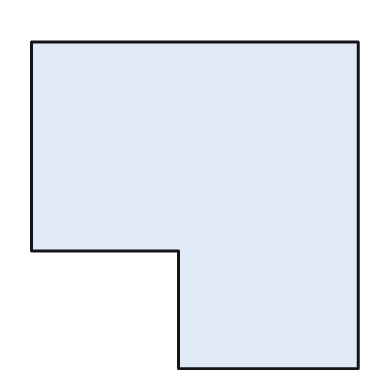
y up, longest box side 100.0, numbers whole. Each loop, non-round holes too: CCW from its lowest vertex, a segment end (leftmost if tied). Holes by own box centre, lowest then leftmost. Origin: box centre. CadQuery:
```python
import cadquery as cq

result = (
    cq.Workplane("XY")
    .moveTo(-5.0, -50.0)
    .lineTo(50.0, -50.0)
    .lineTo(50.0, 50.0)
    .lineTo(-50.0, 50.0)
    .lineTo(-50.0, -14.0)
    .lineTo(-5.0, -14.0)
    .close()
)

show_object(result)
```